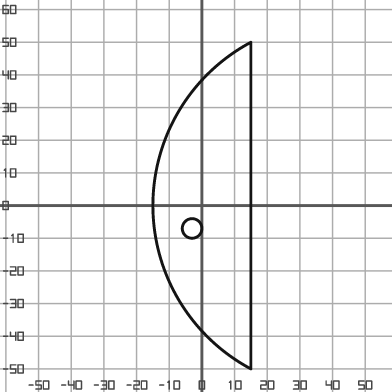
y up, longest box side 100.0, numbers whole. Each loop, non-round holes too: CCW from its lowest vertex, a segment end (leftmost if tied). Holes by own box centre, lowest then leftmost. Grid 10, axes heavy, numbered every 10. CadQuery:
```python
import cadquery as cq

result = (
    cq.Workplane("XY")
    .moveTo(15.0, -50.0)
    .lineTo(15.0, 50.0)
    .threePointArc((-15.0, 0.0), (15.0, -50.0))
    .close()
    .moveTo(-3.0, -7.0)
    .circle(3.0)
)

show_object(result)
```